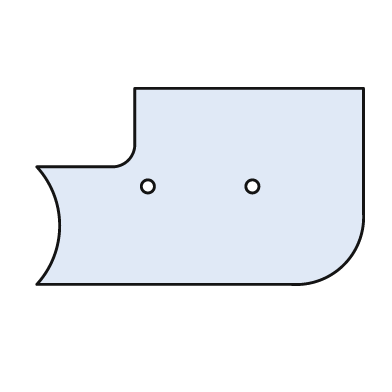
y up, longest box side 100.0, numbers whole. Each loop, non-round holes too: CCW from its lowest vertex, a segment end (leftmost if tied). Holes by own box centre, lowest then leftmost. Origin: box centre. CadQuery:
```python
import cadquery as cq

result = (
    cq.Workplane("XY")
    .moveTo(-50.0, -30.0)
    .lineTo(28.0, -30.0)
    .threePointArc((44.0, -24.0), (50.0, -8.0))
    .lineTo(50.0, 30.0)
    .lineTo(-20.0, 30.0)
    .lineTo(-20.0, 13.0)
    .threePointArc((-22.0, 8.0), (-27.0, 6.0))
    .lineTo(-50.0, 6.0)
    .threePointArc((-43.0, -12.0), (-50.0, -30.0))
    .close()
    .moveTo(-16.0, 0.0)
    .circle(2.0)
    .moveTo(16.0, 0.0)
    .circle(2.0)
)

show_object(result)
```